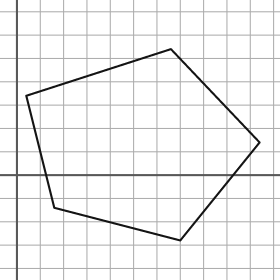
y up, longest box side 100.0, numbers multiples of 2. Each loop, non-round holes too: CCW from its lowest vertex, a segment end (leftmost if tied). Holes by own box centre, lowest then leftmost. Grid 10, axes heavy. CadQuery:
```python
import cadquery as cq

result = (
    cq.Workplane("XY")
    .moveTo(70.0, -28.0)
    .lineTo(104.0, 14.0)
    .lineTo(66.0, 54.0)
    .lineTo(4.0, 34.0)
    .lineTo(16.0, -14.0)
    .close()
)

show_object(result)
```